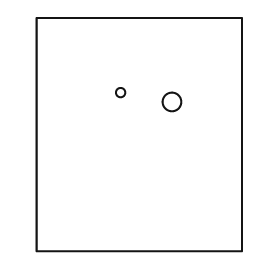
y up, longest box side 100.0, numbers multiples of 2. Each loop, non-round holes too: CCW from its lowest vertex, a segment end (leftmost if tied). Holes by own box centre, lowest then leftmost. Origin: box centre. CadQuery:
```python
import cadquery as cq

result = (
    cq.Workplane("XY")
    .moveTo(-44.0, -50.0)
    .lineTo(44.0, -50.0)
    .lineTo(44.0, 50.0)
    .lineTo(-44.0, 50.0)
    .close()
    .moveTo(14.0, 14.0)
    .circle(4.0)
    .moveTo(-8.0, 18.0)
    .circle(2.0)
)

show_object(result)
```